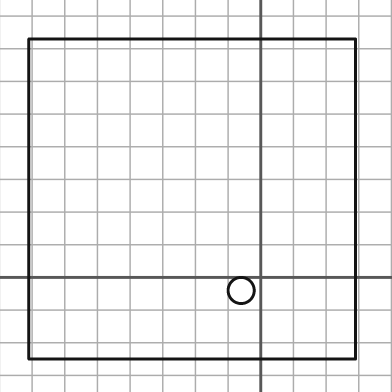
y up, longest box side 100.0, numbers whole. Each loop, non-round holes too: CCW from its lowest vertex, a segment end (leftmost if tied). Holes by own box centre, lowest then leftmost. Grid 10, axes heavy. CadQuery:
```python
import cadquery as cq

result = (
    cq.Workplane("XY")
    .moveTo(-71.0, -25.0)
    .lineTo(29.0, -25.0)
    .lineTo(29.0, 73.0)
    .lineTo(-71.0, 73.0)
    .close()
    .moveTo(-6.0, -4.0)
    .circle(4.0)
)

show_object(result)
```